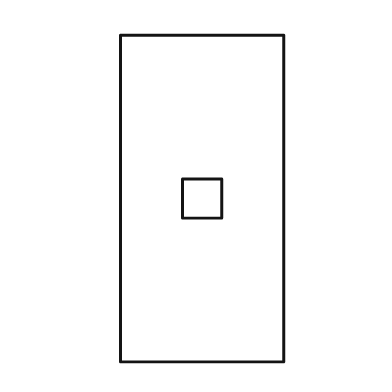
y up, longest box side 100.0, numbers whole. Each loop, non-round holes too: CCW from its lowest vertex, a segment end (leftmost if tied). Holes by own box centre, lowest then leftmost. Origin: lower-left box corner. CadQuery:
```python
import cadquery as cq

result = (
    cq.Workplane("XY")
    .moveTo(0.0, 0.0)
    .lineTo(50.0, 0.0)
    .lineTo(50.0, 100.0)
    .lineTo(0.0, 100.0)
    .close()
    .moveTo(19.0, 44.0)
    .lineTo(31.0, 44.0)
    .lineTo(31.0, 56.0)
    .lineTo(19.0, 56.0)
    .close()
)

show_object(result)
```